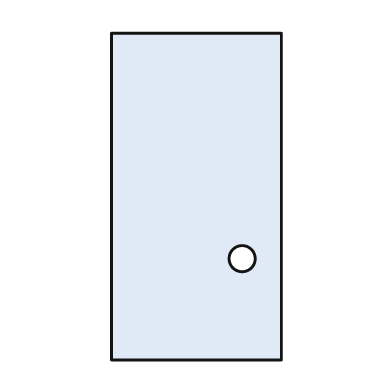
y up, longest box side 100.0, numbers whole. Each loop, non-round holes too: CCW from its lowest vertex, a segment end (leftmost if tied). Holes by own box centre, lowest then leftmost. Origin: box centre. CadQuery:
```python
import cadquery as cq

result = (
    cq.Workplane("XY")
    .moveTo(-26.0, -50.0)
    .lineTo(26.0, -50.0)
    .lineTo(26.0, 50.0)
    .lineTo(-26.0, 50.0)
    .close()
    .moveTo(14.0, -19.0)
    .circle(4.0)
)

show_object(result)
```